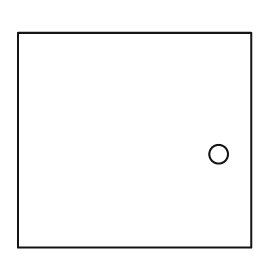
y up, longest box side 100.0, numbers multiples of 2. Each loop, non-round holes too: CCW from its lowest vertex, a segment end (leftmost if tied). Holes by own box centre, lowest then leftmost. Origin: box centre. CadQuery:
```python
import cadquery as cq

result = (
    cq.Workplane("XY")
    .moveTo(-50.0, -46.0)
    .lineTo(50.0, -46.0)
    .lineTo(50.0, 46.0)
    .lineTo(-50.0, 46.0)
    .close()
    .moveTo(36.0, -6.0)
    .circle(4.0)
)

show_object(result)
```